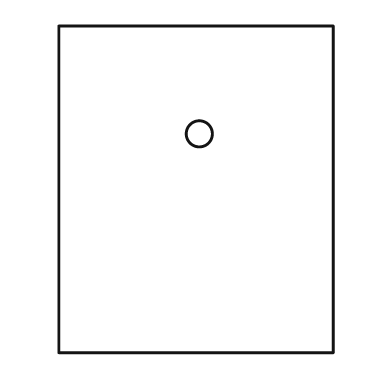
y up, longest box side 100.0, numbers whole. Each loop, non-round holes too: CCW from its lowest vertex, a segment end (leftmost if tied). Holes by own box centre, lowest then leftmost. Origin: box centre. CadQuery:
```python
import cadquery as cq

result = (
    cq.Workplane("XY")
    .moveTo(-42.0, -50.0)
    .lineTo(42.0, -50.0)
    .lineTo(42.0, 50.0)
    .lineTo(-42.0, 50.0)
    .close()
    .moveTo(1.0, 17.0)
    .circle(4.0)
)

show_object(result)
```